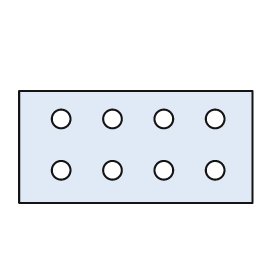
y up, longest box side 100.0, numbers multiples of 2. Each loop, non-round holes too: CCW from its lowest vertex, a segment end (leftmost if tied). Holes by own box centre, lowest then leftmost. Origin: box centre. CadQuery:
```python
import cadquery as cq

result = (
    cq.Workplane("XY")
    .moveTo(-50.0, -24.0)
    .lineTo(50.0, -24.0)
    .lineTo(50.0, 24.0)
    .lineTo(-50.0, 24.0)
    .close()
    .moveTo(-32.0, -10.0)
    .circle(4.0)
    .moveTo(-10.0, -10.0)
    .circle(4.0)
    .moveTo(12.0, -10.0)
    .circle(4.0)
    .moveTo(34.0, -10.0)
    .circle(4.0)
    .moveTo(-32.0, 12.0)
    .circle(4.0)
    .moveTo(-10.0, 12.0)
    .circle(4.0)
    .moveTo(12.0, 12.0)
    .circle(4.0)
    .moveTo(34.0, 12.0)
    .circle(4.0)
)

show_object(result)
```